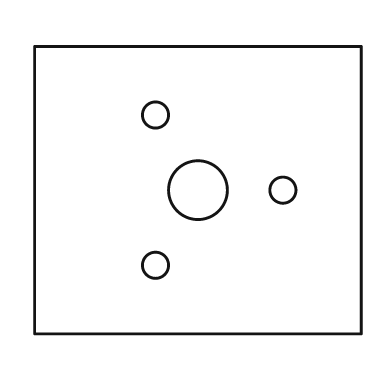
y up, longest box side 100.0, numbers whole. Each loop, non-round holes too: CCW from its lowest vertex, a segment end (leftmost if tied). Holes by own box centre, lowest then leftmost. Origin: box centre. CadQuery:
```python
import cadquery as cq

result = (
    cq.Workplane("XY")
    .moveTo(-50.0, -44.0)
    .lineTo(50.0, -44.0)
    .lineTo(50.0, 44.0)
    .lineTo(-50.0, 44.0)
    .close()
    .moveTo(-13.0, -23.0)
    .circle(4.0)
    .moveTo(0.0, 0.0)
    .circle(9.0)
    .moveTo(26.0, 0.0)
    .circle(4.0)
    .moveTo(-13.0, 23.0)
    .circle(4.0)
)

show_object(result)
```